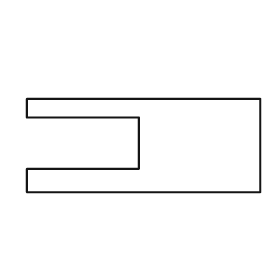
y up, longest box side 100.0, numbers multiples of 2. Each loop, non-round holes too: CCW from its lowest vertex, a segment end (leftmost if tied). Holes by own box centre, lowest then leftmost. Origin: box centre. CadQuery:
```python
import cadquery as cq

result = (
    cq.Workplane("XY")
    .moveTo(-50.0, -20.0)
    .lineTo(50.0, -20.0)
    .lineTo(50.0, 20.0)
    .lineTo(-50.0, 20.0)
    .lineTo(-50.0, 12.0)
    .lineTo(-2.0, 12.0)
    .lineTo(-2.0, -10.0)
    .lineTo(-50.0, -10.0)
    .close()
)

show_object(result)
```